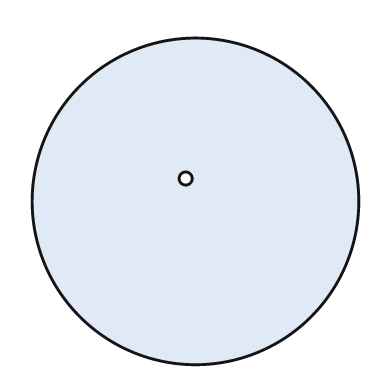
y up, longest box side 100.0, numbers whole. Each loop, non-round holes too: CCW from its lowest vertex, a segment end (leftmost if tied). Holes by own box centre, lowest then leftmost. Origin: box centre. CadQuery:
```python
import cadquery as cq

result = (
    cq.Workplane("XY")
    .moveTo(0.0, 0.0)
    .circle(50.0)
    .moveTo(-3.0, 7.0)
    .circle(2.0)
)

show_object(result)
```